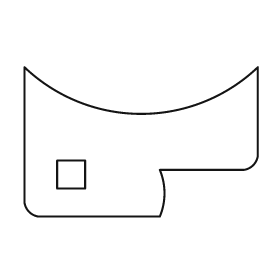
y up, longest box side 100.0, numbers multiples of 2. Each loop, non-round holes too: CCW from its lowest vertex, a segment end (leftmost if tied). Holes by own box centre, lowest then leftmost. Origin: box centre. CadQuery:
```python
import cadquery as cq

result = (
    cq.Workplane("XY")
    .moveTo(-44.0, -32.0)
    .lineTo(8.0, -32.0)
    .threePointArc((10.0, -22.0), (8.0, -12.0))
    .lineTo(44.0, -12.0)
    .threePointArc((48.0, -10.0), (50.0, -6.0))
    .lineTo(50.0, 32.0)
    .threePointArc((0.0, 12.0), (-50.0, 32.0))
    .lineTo(-50.0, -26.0)
    .threePointArc((-48.0, -30.0), (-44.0, -32.0))
    .close()
    .moveTo(-36.0, -20.0)
    .lineTo(-24.0, -20.0)
    .lineTo(-24.0, -8.0)
    .lineTo(-36.0, -8.0)
    .close()
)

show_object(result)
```